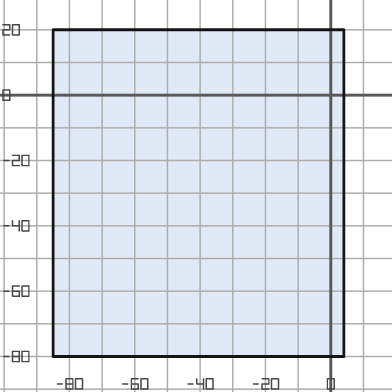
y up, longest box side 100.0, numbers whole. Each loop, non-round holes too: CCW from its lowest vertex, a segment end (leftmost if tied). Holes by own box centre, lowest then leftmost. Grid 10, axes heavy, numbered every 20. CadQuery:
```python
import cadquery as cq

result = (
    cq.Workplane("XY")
    .moveTo(-85.0, -80.0)
    .lineTo(4.0, -80.0)
    .lineTo(4.0, 20.0)
    .lineTo(-85.0, 20.0)
    .close()
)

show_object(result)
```